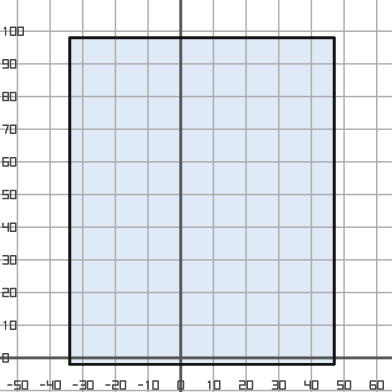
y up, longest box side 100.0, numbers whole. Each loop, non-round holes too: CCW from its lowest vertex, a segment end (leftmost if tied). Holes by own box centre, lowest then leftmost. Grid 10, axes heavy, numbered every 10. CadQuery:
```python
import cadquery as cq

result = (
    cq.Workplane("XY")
    .moveTo(-34.0, -2.0)
    .lineTo(47.0, -2.0)
    .lineTo(47.0, 98.0)
    .lineTo(-34.0, 98.0)
    .close()
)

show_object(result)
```